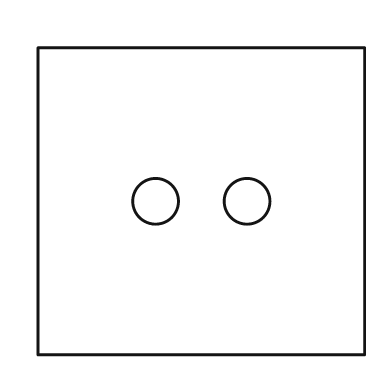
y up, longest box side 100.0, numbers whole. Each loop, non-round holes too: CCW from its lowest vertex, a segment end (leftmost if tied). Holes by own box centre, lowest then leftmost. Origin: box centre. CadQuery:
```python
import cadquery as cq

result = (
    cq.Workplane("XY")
    .moveTo(-50.0, -47.0)
    .lineTo(50.0, -47.0)
    .lineTo(50.0, 47.0)
    .lineTo(-50.0, 47.0)
    .close()
    .moveTo(-14.0, 0.0)
    .circle(7.0)
    .moveTo(14.0, 0.0)
    .circle(7.0)
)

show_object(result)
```